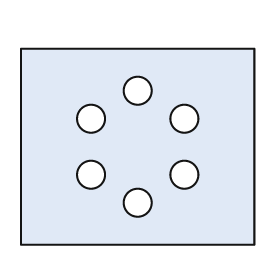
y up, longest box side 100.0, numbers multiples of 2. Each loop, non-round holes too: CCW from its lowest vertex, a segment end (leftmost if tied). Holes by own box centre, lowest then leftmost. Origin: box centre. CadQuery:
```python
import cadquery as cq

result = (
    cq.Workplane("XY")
    .moveTo(-50.0, -42.0)
    .lineTo(50.0, -42.0)
    .lineTo(50.0, 42.0)
    .lineTo(-50.0, 42.0)
    .close()
    .moveTo(0.0, -24.0)
    .circle(6.0)
    .moveTo(-20.0, -12.0)
    .circle(6.0)
    .moveTo(20.0, -12.0)
    .circle(6.0)
    .moveTo(-20.0, 12.0)
    .circle(6.0)
    .moveTo(20.0, 12.0)
    .circle(6.0)
    .moveTo(0.0, 24.0)
    .circle(6.0)
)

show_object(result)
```